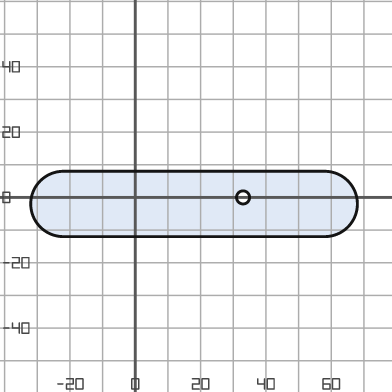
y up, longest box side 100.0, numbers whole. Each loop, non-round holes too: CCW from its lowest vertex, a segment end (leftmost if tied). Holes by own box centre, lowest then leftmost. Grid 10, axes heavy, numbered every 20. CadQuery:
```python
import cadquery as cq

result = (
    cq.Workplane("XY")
    .moveTo(-22.0, -12.0)
    .lineTo(58.0, -12.0)
    .threePointArc((68.0, -2.0), (58.0, 8.0))
    .lineTo(-22.0, 8.0)
    .threePointArc((-32.0, -2.0), (-22.0, -12.0))
    .close()
    .moveTo(33.0, 0.0)
    .circle(2.0)
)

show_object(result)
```